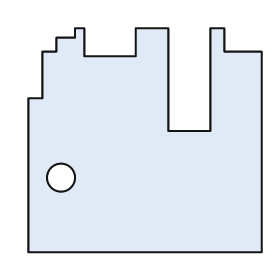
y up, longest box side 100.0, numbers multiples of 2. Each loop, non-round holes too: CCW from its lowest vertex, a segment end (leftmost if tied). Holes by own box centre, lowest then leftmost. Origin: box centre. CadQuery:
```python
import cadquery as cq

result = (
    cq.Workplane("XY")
    .moveTo(-50.0, -48.0)
    .lineTo(50.0, -48.0)
    .lineTo(50.0, 38.0)
    .lineTo(34.0, 38.0)
    .lineTo(34.0, 48.0)
    .lineTo(28.0, 48.0)
    .lineTo(28.0, 4.0)
    .lineTo(10.0, 4.0)
    .lineTo(10.0, 48.0)
    .lineTo(-4.0, 48.0)
    .lineTo(-4.0, 36.0)
    .lineTo(-26.0, 36.0)
    .lineTo(-26.0, 48.0)
    .lineTo(-30.0, 48.0)
    .lineTo(-30.0, 44.0)
    .lineTo(-38.0, 44.0)
    .lineTo(-38.0, 38.0)
    .lineTo(-44.0, 38.0)
    .lineTo(-44.0, 18.0)
    .lineTo(-50.0, 18.0)
    .close()
    .moveTo(-36.0, -16.0)
    .circle(6.0)
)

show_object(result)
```